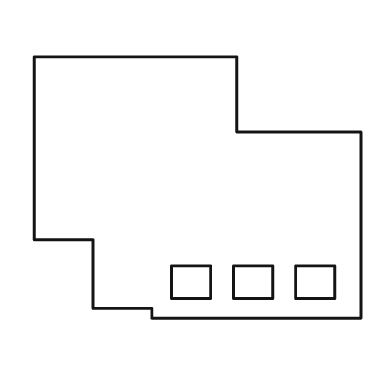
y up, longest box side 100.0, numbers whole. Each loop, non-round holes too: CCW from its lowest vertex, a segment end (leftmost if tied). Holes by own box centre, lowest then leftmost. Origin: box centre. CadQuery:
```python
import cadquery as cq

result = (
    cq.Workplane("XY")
    .moveTo(-14.0, -40.0)
    .lineTo(50.0, -40.0)
    .lineTo(50.0, 17.0)
    .lineTo(12.0, 17.0)
    .lineTo(12.0, 40.0)
    .lineTo(-50.0, 40.0)
    .lineTo(-50.0, -16.0)
    .lineTo(-32.0, -16.0)
    .lineTo(-32.0, -37.0)
    .lineTo(-14.0, -37.0)
    .close()
    .moveTo(-8.0, -34.0)
    .lineTo(4.0, -34.0)
    .lineTo(4.0, -24.0)
    .lineTo(-8.0, -24.0)
    .close()
    .moveTo(11.0, -34.0)
    .lineTo(23.0, -34.0)
    .lineTo(23.0, -24.0)
    .lineTo(11.0, -24.0)
    .close()
    .moveTo(30.0, -34.0)
    .lineTo(42.0, -34.0)
    .lineTo(42.0, -24.0)
    .lineTo(30.0, -24.0)
    .close()
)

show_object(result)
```